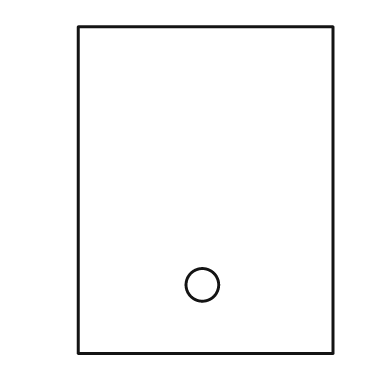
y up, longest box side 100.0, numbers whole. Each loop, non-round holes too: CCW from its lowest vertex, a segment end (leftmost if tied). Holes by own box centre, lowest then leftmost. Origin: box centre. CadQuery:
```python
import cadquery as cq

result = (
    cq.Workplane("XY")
    .moveTo(-39.0, -50.0)
    .lineTo(39.0, -50.0)
    .lineTo(39.0, 50.0)
    .lineTo(-39.0, 50.0)
    .close()
    .moveTo(-1.0, -29.0)
    .circle(5.0)
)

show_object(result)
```